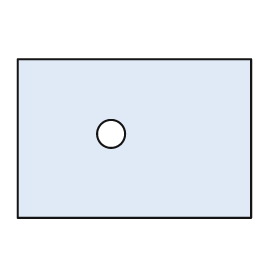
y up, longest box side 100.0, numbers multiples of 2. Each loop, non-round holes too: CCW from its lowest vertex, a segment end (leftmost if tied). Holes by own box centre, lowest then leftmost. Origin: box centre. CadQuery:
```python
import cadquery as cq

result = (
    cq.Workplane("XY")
    .moveTo(-50.0, -34.0)
    .lineTo(50.0, -34.0)
    .lineTo(50.0, 34.0)
    .lineTo(-50.0, 34.0)
    .close()
    .moveTo(-10.0, 2.0)
    .circle(6.0)
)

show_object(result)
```